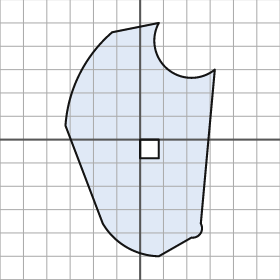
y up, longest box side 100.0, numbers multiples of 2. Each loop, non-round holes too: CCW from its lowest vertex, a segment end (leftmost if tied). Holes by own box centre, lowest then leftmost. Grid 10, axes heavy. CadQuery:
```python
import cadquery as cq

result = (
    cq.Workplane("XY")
    .moveTo(8.0, -50.0)
    .lineTo(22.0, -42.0)
    .threePointArc((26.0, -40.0), (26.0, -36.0))
    .lineTo(32.0, 30.0)
    .threePointArc((12.0, 30.0), (8.0, 50.0))
    .lineTo(-12.0, 46.0)
    .threePointArc((-26.0, 28.0), (-32.0, 6.0))
    .lineTo(-16.0, -36.0)
    .threePointArc((-6.0, -46.0), (8.0, -50.0))
    .close()
    .moveTo(0.0, -8.0)
    .lineTo(8.0, -8.0)
    .lineTo(8.0, 0.0)
    .lineTo(0.0, 0.0)
    .close()
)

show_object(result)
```